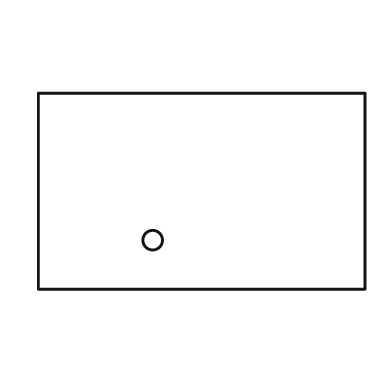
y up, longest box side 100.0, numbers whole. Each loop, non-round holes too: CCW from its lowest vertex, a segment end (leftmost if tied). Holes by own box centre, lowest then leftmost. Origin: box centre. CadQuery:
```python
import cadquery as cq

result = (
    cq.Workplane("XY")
    .moveTo(-50.0, -30.0)
    .lineTo(50.0, -30.0)
    .lineTo(50.0, 30.0)
    .lineTo(-50.0, 30.0)
    .close()
    .moveTo(-15.0, -15.0)
    .circle(3.0)
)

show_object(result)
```